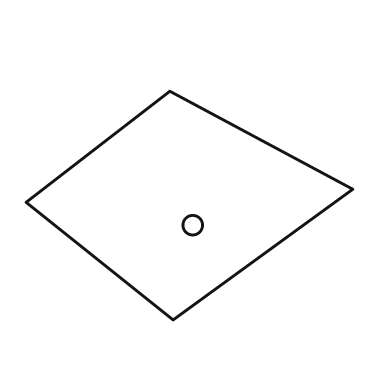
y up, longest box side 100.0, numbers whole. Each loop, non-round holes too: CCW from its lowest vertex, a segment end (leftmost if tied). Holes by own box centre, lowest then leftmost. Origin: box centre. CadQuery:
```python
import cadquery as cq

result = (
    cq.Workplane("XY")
    .moveTo(-5.0, -35.0)
    .lineTo(50.0, 5.0)
    .lineTo(-6.0, 35.0)
    .lineTo(-50.0, 1.0)
    .close()
    .moveTo(1.0, -6.0)
    .circle(3.0)
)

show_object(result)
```